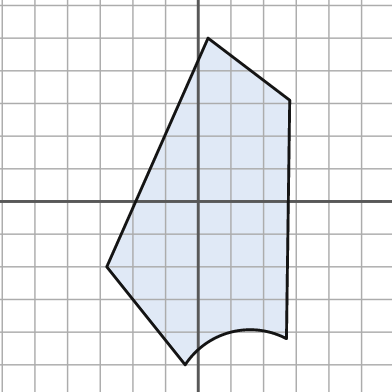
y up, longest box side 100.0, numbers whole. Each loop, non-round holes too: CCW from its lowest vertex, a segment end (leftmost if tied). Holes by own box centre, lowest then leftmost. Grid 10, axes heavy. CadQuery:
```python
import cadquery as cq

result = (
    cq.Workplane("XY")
    .moveTo(-4.0, -50.0)
    .threePointArc((10.0, -40.0), (27.0, -42.0))
    .lineTo(28.0, 31.0)
    .lineTo(3.0, 50.0)
    .lineTo(-28.0, -20.0)
    .close()
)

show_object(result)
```